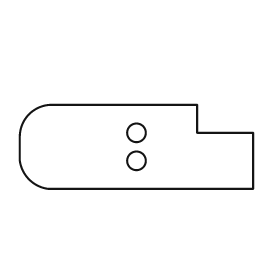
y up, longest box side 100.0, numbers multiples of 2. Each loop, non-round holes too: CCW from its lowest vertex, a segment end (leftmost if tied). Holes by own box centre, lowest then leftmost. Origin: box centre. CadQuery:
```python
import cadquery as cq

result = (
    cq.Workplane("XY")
    .moveTo(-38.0, -18.0)
    .lineTo(50.0, -18.0)
    .lineTo(50.0, 6.0)
    .lineTo(26.0, 6.0)
    .lineTo(26.0, 18.0)
    .lineTo(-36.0, 18.0)
    .threePointArc((-46.0, 14.0), (-50.0, 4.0))
    .lineTo(-50.0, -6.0)
    .threePointArc((-46.0, -14.0), (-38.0, -18.0))
    .close()
    .moveTo(0.0, -6.0)
    .circle(4.0)
    .moveTo(0.0, 6.0)
    .circle(4.0)
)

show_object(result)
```